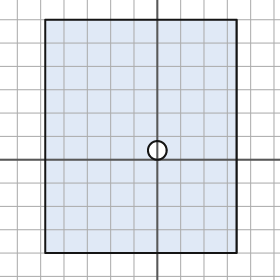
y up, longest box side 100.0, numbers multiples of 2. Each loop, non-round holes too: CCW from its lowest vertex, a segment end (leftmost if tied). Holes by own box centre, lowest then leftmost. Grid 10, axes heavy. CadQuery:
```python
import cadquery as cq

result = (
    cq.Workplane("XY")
    .moveTo(-48.0, -40.0)
    .lineTo(34.0, -40.0)
    .lineTo(34.0, 60.0)
    .lineTo(-48.0, 60.0)
    .close()
    .moveTo(0.0, 4.0)
    .circle(4.0)
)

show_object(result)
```